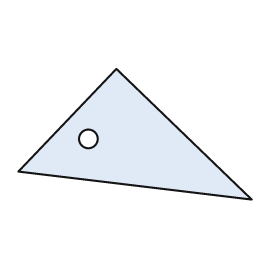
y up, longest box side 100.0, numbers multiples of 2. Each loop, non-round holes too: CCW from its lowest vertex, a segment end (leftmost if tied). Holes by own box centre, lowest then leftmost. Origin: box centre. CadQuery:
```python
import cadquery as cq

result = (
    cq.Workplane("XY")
    .moveTo(50.0, -28.0)
    .lineTo(-8.0, 28.0)
    .lineTo(-50.0, -16.0)
    .close()
    .moveTo(-20.0, -2.0)
    .circle(4.0)
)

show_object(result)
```